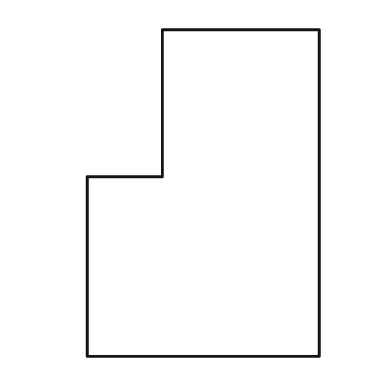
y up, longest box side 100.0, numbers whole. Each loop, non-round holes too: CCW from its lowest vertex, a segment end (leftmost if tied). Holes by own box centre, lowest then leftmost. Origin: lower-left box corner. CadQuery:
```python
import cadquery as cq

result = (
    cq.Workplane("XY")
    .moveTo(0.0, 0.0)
    .lineTo(71.0, 0.0)
    .lineTo(71.0, 100.0)
    .lineTo(23.0, 100.0)
    .lineTo(23.0, 55.0)
    .lineTo(0.0, 55.0)
    .close()
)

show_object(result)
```